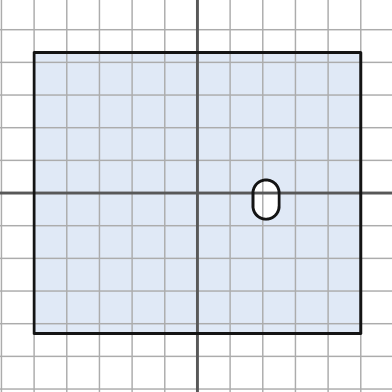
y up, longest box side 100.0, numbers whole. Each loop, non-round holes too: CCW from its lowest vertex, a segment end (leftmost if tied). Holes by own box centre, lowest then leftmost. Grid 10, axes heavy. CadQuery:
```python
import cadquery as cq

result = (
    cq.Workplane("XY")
    .moveTo(-50.0, -43.0)
    .lineTo(50.0, -43.0)
    .lineTo(50.0, 43.0)
    .lineTo(-50.0, 43.0)
    .close()
    .moveTo(17.0, -4.0)
    .threePointArc((21.0, -8.0), (25.0, -4.0))
    .lineTo(25.0, 0.0)
    .threePointArc((21.0, 4.0), (17.0, 0.0))
    .close()
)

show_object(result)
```